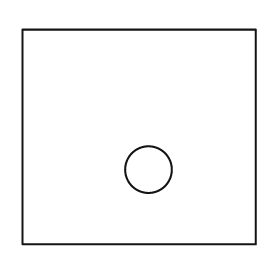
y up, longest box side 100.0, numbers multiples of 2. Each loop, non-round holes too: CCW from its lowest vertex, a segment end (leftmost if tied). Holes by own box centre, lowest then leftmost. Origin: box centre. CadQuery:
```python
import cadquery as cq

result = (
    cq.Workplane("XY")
    .moveTo(-50.0, -46.0)
    .lineTo(50.0, -46.0)
    .lineTo(50.0, 46.0)
    .lineTo(-50.0, 46.0)
    .close()
    .moveTo(4.0, -14.0)
    .circle(10.0)
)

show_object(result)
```